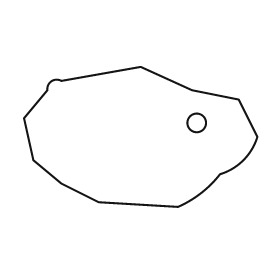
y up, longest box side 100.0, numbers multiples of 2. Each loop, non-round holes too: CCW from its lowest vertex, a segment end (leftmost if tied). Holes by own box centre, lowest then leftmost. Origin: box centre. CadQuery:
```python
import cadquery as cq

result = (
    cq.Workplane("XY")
    .moveTo(16.0, -30.0)
    .threePointArc((26.0, -24.0), (34.0, -16.0))
    .threePointArc((44.0, -10.0), (50.0, 0.0))
    .lineTo(42.0, 16.0)
    .lineTo(22.0, 20.0)
    .lineTo(0.0, 30.0)
    .lineTo(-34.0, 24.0)
    .threePointArc((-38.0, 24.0), (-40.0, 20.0))
    .lineTo(-50.0, 8.0)
    .lineTo(-46.0, -10.0)
    .lineTo(-34.0, -20.0)
    .lineTo(-18.0, -28.0)
    .close()
    .moveTo(24.0, 6.0)
    .circle(4.0)
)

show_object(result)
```